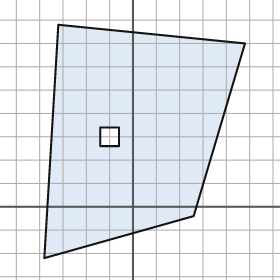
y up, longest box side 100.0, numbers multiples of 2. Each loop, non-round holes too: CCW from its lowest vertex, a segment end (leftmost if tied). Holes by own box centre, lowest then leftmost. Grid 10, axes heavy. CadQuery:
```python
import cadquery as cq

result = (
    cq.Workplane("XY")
    .moveTo(-38.0, -22.0)
    .lineTo(26.0, -4.0)
    .lineTo(48.0, 70.0)
    .lineTo(-32.0, 78.0)
    .close()
    .moveTo(-14.0, 26.0)
    .lineTo(-6.0, 26.0)
    .lineTo(-6.0, 34.0)
    .lineTo(-14.0, 34.0)
    .close()
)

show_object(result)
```